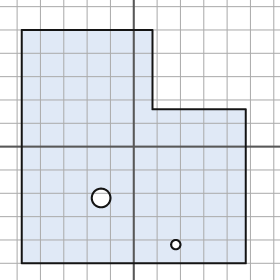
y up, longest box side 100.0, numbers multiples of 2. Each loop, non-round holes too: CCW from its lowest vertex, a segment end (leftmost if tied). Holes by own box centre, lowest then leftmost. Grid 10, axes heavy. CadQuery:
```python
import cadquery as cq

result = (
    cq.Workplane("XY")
    .moveTo(-48.0, -50.0)
    .lineTo(48.0, -50.0)
    .lineTo(48.0, 16.0)
    .lineTo(8.0, 16.0)
    .lineTo(8.0, 50.0)
    .lineTo(-48.0, 50.0)
    .close()
    .moveTo(18.0, -42.0)
    .circle(2.0)
    .moveTo(-14.0, -22.0)
    .circle(4.0)
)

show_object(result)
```